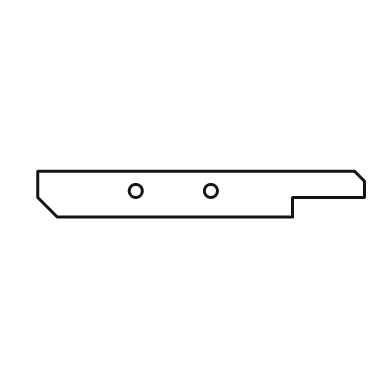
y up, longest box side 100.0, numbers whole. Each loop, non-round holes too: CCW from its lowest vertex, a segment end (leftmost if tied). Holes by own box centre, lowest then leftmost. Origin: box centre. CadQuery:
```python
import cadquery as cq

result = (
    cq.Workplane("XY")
    .moveTo(-44.0, -7.0)
    .lineTo(28.0, -7.0)
    .lineTo(28.0, -1.0)
    .lineTo(50.0, -1.0)
    .lineTo(50.0, 4.0)
    .lineTo(47.0, 7.0)
    .lineTo(-50.0, 7.0)
    .lineTo(-50.0, -1.0)
    .close()
    .moveTo(-20.0, 1.0)
    .circle(2.0)
    .moveTo(3.0, 1.0)
    .circle(2.0)
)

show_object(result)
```